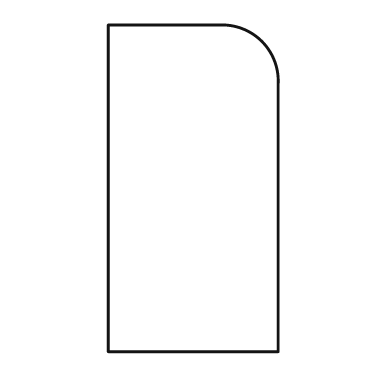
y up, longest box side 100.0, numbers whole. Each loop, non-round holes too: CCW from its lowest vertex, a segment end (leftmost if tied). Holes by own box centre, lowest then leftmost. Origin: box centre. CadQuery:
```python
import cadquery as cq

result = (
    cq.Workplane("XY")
    .moveTo(-26.0, -50.0)
    .lineTo(26.0, -50.0)
    .lineTo(26.0, 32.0)
    .threePointArc((21.0, 45.0), (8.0, 50.0))
    .lineTo(-26.0, 50.0)
    .close()
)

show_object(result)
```